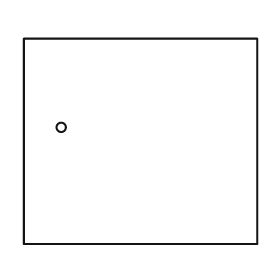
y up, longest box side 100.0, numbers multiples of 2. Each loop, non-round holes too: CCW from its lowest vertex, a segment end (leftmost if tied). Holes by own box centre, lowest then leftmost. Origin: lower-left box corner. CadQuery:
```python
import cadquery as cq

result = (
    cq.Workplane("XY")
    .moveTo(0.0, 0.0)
    .lineTo(100.0, 0.0)
    .lineTo(100.0, 88.0)
    .lineTo(0.0, 88.0)
    .close()
    .moveTo(16.0, 50.0)
    .circle(2.0)
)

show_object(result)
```